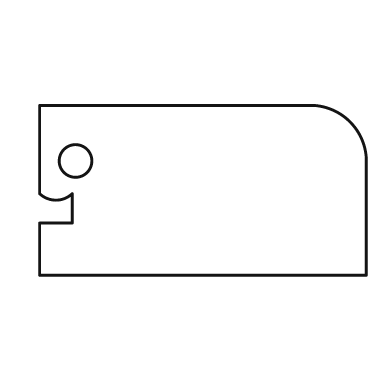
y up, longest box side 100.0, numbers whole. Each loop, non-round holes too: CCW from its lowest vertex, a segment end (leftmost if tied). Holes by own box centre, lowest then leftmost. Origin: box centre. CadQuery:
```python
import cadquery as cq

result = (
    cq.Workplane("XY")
    .moveTo(-50.0, -26.0)
    .lineTo(50.0, -26.0)
    .lineTo(50.0, 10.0)
    .threePointArc((45.0, 21.0), (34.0, 26.0))
    .lineTo(-50.0, 26.0)
    .lineTo(-50.0, -1.0)
    .threePointArc((-45.0, -3.0), (-40.0, -1.0))
    .lineTo(-40.0, -10.0)
    .lineTo(-50.0, -10.0)
    .close()
    .moveTo(-39.0, 9.0)
    .circle(5.0)
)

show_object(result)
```